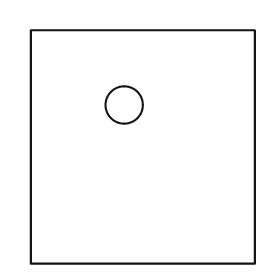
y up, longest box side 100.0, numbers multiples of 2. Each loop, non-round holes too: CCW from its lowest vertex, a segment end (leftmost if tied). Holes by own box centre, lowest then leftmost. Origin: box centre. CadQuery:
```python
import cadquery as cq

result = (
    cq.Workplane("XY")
    .moveTo(-48.0, -50.0)
    .lineTo(48.0, -50.0)
    .lineTo(48.0, 50.0)
    .lineTo(-48.0, 50.0)
    .close()
    .moveTo(-8.0, 18.0)
    .circle(8.0)
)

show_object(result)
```